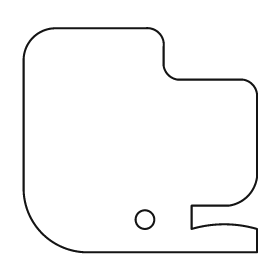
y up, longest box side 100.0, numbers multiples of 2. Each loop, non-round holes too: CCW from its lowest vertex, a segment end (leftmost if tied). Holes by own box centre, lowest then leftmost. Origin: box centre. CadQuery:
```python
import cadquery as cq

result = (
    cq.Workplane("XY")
    .moveTo(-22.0, -48.0)
    .lineTo(50.0, -48.0)
    .lineTo(50.0, -38.0)
    .threePointArc((36.0, -36.0), (22.0, -38.0))
    .lineTo(22.0, -28.0)
    .lineTo(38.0, -28.0)
    .threePointArc((46.0, -24.0), (50.0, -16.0))
    .lineTo(50.0, 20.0)
    .threePointArc((48.0, 24.0), (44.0, 26.0))
    .lineTo(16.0, 26.0)
    .threePointArc((12.0, 28.0), (10.0, 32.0))
    .lineTo(10.0, 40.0)
    .threePointArc((8.0, 46.0), (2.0, 48.0))
    .lineTo(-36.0, 48.0)
    .threePointArc((-46.0, 44.0), (-50.0, 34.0))
    .lineTo(-50.0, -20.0)
    .threePointArc((-42.0, -40.0), (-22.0, -48.0))
    .close()
    .moveTo(2.0, -34.0)
    .circle(4.0)
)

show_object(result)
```